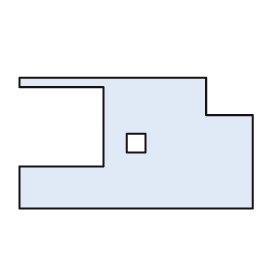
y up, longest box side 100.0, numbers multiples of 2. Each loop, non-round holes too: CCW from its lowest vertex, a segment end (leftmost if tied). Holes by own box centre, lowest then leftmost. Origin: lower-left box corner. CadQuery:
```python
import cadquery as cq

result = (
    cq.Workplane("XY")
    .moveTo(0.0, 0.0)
    .lineTo(100.0, 0.0)
    .lineTo(100.0, 40.0)
    .lineTo(80.0, 40.0)
    .lineTo(80.0, 56.0)
    .lineTo(0.0, 56.0)
    .lineTo(0.0, 52.0)
    .lineTo(36.0, 52.0)
    .lineTo(36.0, 18.0)
    .lineTo(0.0, 18.0)
    .close()
    .moveTo(46.0, 24.0)
    .lineTo(54.0, 24.0)
    .lineTo(54.0, 32.0)
    .lineTo(46.0, 32.0)
    .close()
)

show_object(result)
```